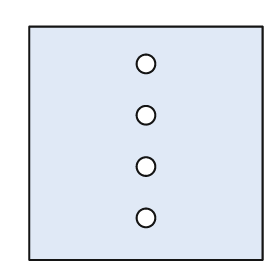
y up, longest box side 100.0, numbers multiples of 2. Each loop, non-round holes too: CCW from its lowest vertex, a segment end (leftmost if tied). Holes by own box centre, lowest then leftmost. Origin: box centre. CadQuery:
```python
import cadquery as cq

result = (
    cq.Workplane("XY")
    .moveTo(-50.0, -50.0)
    .lineTo(50.0, -50.0)
    .lineTo(50.0, 50.0)
    .lineTo(-50.0, 50.0)
    .close()
    .moveTo(0.0, -32.0)
    .circle(4.0)
    .moveTo(0.0, -10.0)
    .circle(4.0)
    .moveTo(0.0, 12.0)
    .circle(4.0)
    .moveTo(0.0, 34.0)
    .circle(4.0)
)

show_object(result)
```